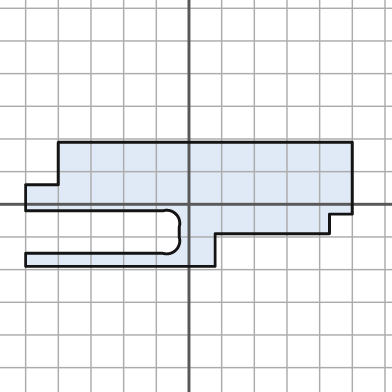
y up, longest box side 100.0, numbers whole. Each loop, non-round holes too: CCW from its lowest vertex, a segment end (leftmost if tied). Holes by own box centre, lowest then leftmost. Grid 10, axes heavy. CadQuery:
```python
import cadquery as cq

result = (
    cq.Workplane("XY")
    .moveTo(-50.0, -19.0)
    .lineTo(8.0, -19.0)
    .lineTo(8.0, -9.0)
    .lineTo(43.0, -9.0)
    .lineTo(43.0, -3.0)
    .lineTo(50.0, -3.0)
    .lineTo(50.0, 19.0)
    .lineTo(-40.0, 19.0)
    .lineTo(-40.0, 6.0)
    .lineTo(-50.0, 6.0)
    .lineTo(-50.0, -2.0)
    .lineTo(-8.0, -2.0)
    .threePointArc((-4.0, -3.0), (-3.0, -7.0))
    .lineTo(-3.0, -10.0)
    .threePointArc((-4.0, -14.0), (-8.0, -15.0))
    .lineTo(-50.0, -15.0)
    .close()
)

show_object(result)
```